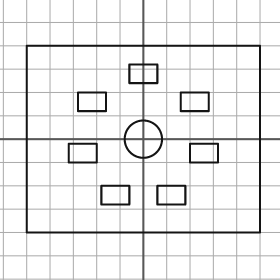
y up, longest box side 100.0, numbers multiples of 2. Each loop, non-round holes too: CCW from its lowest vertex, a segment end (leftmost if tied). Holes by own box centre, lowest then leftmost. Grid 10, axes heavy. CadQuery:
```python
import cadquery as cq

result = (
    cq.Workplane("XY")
    .moveTo(-50.0, -40.0)
    .lineTo(50.0, -40.0)
    .lineTo(50.0, 40.0)
    .lineTo(-50.0, 40.0)
    .close()
    .moveTo(-18.0, -28.0)
    .lineTo(-6.0, -28.0)
    .lineTo(-6.0, -20.0)
    .lineTo(-18.0, -20.0)
    .close()
    .moveTo(6.0, -28.0)
    .lineTo(18.0, -28.0)
    .lineTo(18.0, -20.0)
    .lineTo(6.0, -20.0)
    .close()
    .moveTo(-32.0, -10.0)
    .lineTo(-20.0, -10.0)
    .lineTo(-20.0, -2.0)
    .lineTo(-32.0, -2.0)
    .close()
    .moveTo(20.0, -10.0)
    .lineTo(32.0, -10.0)
    .lineTo(32.0, -2.0)
    .lineTo(20.0, -2.0)
    .close()
    .moveTo(0.0, 0.0)
    .circle(8.0)
    .moveTo(-28.0, 12.0)
    .lineTo(-16.0, 12.0)
    .lineTo(-16.0, 20.0)
    .lineTo(-28.0, 20.0)
    .close()
    .moveTo(16.0, 12.0)
    .lineTo(28.0, 12.0)
    .lineTo(28.0, 20.0)
    .lineTo(16.0, 20.0)
    .close()
    .moveTo(-6.0, 24.0)
    .lineTo(6.0, 24.0)
    .lineTo(6.0, 32.0)
    .lineTo(-6.0, 32.0)
    .close()
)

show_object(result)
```